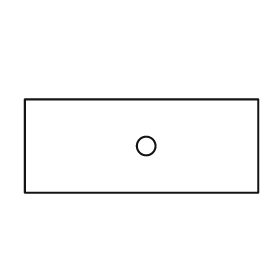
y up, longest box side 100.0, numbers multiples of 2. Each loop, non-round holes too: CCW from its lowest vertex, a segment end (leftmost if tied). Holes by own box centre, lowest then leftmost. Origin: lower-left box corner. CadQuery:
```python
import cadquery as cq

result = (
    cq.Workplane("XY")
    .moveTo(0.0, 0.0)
    .lineTo(100.0, 0.0)
    .lineTo(100.0, 40.0)
    .lineTo(0.0, 40.0)
    .close()
    .moveTo(52.0, 20.0)
    .circle(4.0)
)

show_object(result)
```